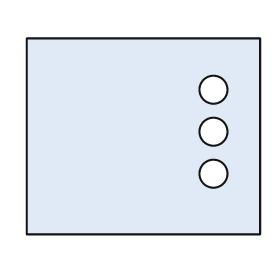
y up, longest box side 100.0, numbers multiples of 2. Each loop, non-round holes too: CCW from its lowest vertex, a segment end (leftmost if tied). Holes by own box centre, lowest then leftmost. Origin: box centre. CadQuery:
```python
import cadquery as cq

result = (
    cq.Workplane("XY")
    .moveTo(-50.0, -42.0)
    .lineTo(50.0, -42.0)
    .lineTo(50.0, 42.0)
    .lineTo(-50.0, 42.0)
    .close()
    .moveTo(30.0, -16.0)
    .circle(6.0)
    .moveTo(30.0, 2.0)
    .circle(6.0)
    .moveTo(30.0, 20.0)
    .circle(6.0)
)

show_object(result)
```